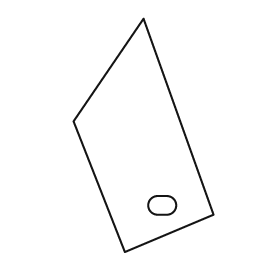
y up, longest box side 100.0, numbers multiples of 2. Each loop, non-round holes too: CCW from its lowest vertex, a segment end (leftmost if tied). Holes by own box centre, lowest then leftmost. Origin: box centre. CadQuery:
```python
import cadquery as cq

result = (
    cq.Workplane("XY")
    .moveTo(-8.0, -50.0)
    .lineTo(30.0, -34.0)
    .lineTo(0.0, 50.0)
    .lineTo(-30.0, 6.0)
    .close()
    .moveTo(6.0, -34.0)
    .lineTo(10.0, -34.0)
    .threePointArc((14.0, -30.0), (10.0, -26.0))
    .lineTo(6.0, -26.0)
    .threePointArc((2.0, -30.0), (6.0, -34.0))
    .close()
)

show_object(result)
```